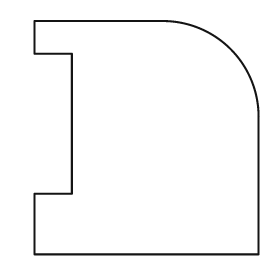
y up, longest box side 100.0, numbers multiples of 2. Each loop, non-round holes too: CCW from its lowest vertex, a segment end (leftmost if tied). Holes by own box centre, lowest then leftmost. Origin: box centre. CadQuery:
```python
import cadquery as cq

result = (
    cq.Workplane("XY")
    .moveTo(-48.0, -50.0)
    .lineTo(48.0, -50.0)
    .lineTo(48.0, 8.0)
    .threePointArc((36.0, 38.0), (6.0, 50.0))
    .lineTo(-48.0, 50.0)
    .lineTo(-48.0, 36.0)
    .lineTo(-32.0, 36.0)
    .lineTo(-32.0, -24.0)
    .lineTo(-48.0, -24.0)
    .close()
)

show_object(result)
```